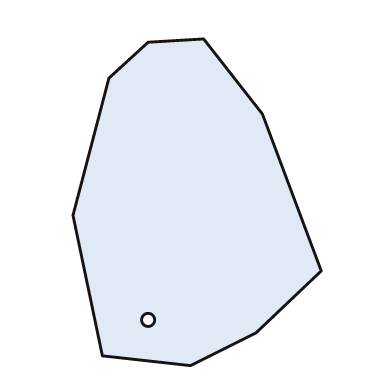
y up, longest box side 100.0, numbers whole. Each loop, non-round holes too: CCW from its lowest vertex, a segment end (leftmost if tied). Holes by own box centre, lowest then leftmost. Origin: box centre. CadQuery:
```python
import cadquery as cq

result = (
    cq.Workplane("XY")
    .moveTo(-2.0, -50.0)
    .lineTo(18.0, -40.0)
    .lineTo(38.0, -21.0)
    .lineTo(20.0, 27.0)
    .lineTo(2.0, 50.0)
    .lineTo(-15.0, 49.0)
    .lineTo(-27.0, 38.0)
    .lineTo(-38.0, -4.0)
    .lineTo(-29.0, -47.0)
    .close()
    .moveTo(-15.0, -36.0)
    .circle(2.0)
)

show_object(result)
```